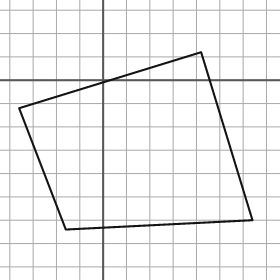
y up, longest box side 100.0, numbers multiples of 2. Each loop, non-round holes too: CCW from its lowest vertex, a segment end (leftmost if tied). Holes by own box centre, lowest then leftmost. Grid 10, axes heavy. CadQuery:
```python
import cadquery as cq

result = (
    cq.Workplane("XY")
    .moveTo(-16.0, -64.0)
    .lineTo(64.0, -60.0)
    .lineTo(42.0, 12.0)
    .lineTo(-36.0, -12.0)
    .close()
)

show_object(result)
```